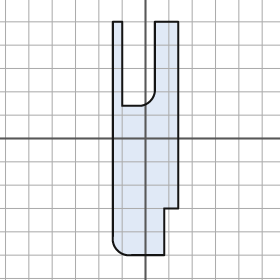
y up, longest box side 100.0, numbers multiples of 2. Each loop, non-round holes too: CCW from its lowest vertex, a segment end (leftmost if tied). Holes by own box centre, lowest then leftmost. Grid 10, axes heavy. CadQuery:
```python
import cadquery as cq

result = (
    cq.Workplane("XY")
    .moveTo(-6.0, -50.0)
    .lineTo(8.0, -50.0)
    .lineTo(8.0, -30.0)
    .lineTo(14.0, -30.0)
    .lineTo(14.0, 50.0)
    .lineTo(4.0, 50.0)
    .lineTo(4.0, 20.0)
    .threePointArc((2.0, 16.0), (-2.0, 14.0))
    .lineTo(-10.0, 14.0)
    .lineTo(-10.0, 50.0)
    .lineTo(-14.0, 50.0)
    .lineTo(-14.0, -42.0)
    .threePointArc((-12.0, -48.0), (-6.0, -50.0))
    .close()
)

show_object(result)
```